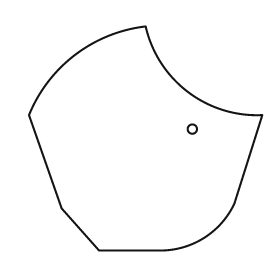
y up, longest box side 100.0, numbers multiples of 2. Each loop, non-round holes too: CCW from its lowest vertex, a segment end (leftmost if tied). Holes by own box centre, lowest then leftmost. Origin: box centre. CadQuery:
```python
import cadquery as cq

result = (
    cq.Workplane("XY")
    .moveTo(-20.0, -48.0)
    .lineTo(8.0, -48.0)
    .threePointArc((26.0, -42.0), (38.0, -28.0))
    .lineTo(50.0, 10.0)
    .threePointArc((18.0, 20.0), (0.0, 48.0))
    .threePointArc((-30.0, 36.0), (-50.0, 10.0))
    .lineTo(-36.0, -30.0)
    .close()
    .moveTo(20.0, 4.0)
    .circle(2.0)
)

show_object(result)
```